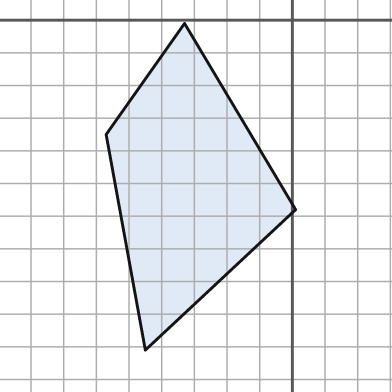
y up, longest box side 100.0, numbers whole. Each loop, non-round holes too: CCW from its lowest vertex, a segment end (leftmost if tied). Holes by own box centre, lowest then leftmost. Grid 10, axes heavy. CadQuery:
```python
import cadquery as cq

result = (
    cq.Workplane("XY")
    .moveTo(-45.0, -101.0)
    .lineTo(1.0, -58.0)
    .lineTo(-33.0, -1.0)
    .lineTo(-57.0, -35.0)
    .close()
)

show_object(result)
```